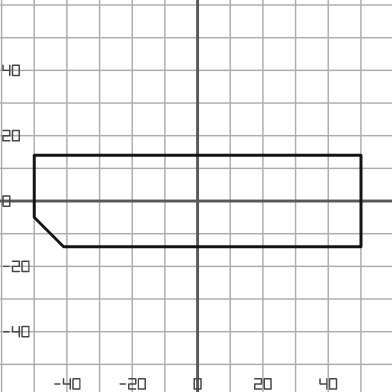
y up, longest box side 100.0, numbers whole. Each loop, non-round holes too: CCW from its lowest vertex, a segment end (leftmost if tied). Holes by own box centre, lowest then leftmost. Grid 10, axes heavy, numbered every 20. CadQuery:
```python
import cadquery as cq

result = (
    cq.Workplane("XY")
    .moveTo(-41.0, -14.0)
    .lineTo(50.0, -14.0)
    .lineTo(50.0, 14.0)
    .lineTo(-50.0, 14.0)
    .lineTo(-50.0, -5.0)
    .close()
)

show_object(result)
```